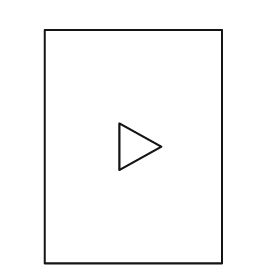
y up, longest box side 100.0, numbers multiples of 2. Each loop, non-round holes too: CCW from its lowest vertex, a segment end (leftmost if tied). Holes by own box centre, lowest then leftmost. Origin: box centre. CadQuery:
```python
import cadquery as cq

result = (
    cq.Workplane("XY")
    .moveTo(-38.0, -50.0)
    .lineTo(38.0, -50.0)
    .lineTo(38.0, 50.0)
    .lineTo(-38.0, 50.0)
    .close()
    .moveTo(-6.0, -10.0)
    .lineTo(12.0, 0.0)
    .lineTo(-6.0, 10.0)
    .close()
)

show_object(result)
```